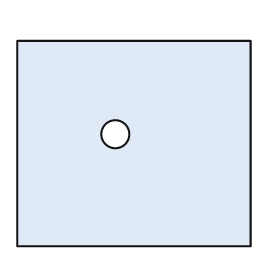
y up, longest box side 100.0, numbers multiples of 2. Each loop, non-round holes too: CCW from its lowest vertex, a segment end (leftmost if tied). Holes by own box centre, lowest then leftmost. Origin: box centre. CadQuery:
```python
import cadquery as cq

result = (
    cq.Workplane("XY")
    .moveTo(-50.0, -44.0)
    .lineTo(50.0, -44.0)
    .lineTo(50.0, 44.0)
    .lineTo(-50.0, 44.0)
    .close()
    .moveTo(-8.0, 4.0)
    .circle(6.0)
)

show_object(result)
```